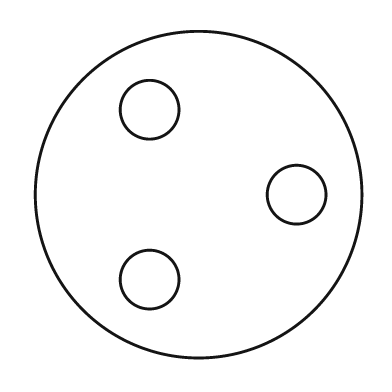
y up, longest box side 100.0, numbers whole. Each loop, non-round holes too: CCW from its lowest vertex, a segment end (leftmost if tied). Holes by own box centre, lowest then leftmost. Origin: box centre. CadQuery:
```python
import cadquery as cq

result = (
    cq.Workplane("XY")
    .moveTo(0.0, 0.0)
    .circle(50.0)
    .moveTo(-15.0, -26.0)
    .circle(9.0)
    .moveTo(30.0, 0.0)
    .circle(9.0)
    .moveTo(-15.0, 26.0)
    .circle(9.0)
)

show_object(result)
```